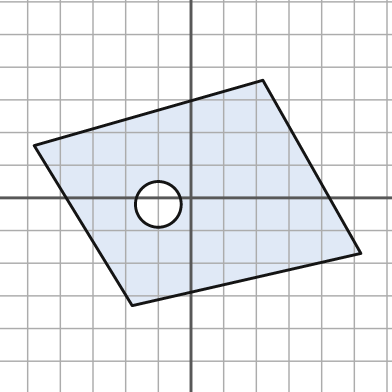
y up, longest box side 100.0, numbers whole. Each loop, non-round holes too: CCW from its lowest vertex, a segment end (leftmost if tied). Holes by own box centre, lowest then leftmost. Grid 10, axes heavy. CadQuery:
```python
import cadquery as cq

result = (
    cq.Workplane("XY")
    .moveTo(-18.0, -33.0)
    .lineTo(52.0, -17.0)
    .lineTo(22.0, 36.0)
    .lineTo(-48.0, 16.0)
    .close()
    .moveTo(-10.0, -2.0)
    .circle(7.0)
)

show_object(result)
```